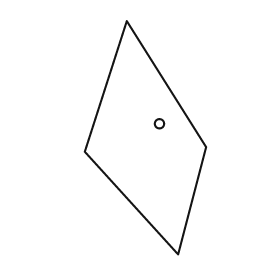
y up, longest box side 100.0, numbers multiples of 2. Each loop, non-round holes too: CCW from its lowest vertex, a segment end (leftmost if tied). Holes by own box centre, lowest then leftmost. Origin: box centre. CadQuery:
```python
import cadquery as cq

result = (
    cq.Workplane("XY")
    .moveTo(14.0, -50.0)
    .lineTo(26.0, -4.0)
    .lineTo(-8.0, 50.0)
    .lineTo(-26.0, -6.0)
    .close()
    .moveTo(6.0, 6.0)
    .circle(2.0)
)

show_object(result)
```